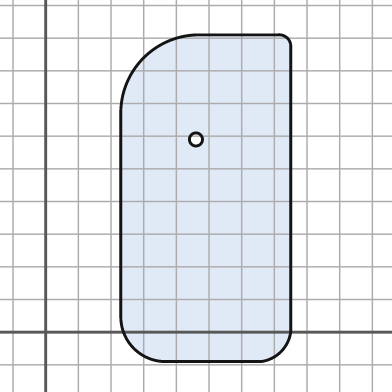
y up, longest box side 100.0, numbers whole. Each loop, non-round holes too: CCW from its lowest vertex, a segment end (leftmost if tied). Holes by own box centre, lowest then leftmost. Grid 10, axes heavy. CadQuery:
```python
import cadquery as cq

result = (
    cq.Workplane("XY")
    .moveTo(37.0, -9.0)
    .lineTo(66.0, -9.0)
    .threePointArc((72.0, -6.0), (75.0, 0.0))
    .lineTo(75.0, 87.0)
    .threePointArc((74.0, 90.0), (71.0, 91.0))
    .lineTo(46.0, 91.0)
    .threePointArc((30.0, 84.0), (23.0, 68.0))
    .lineTo(23.0, 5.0)
    .threePointArc((27.0, -5.0), (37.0, -9.0))
    .close()
    .moveTo(46.0, 59.0)
    .circle(2.0)
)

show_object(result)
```